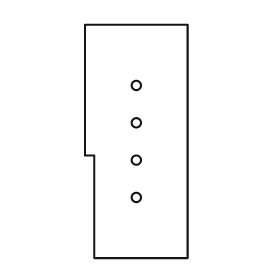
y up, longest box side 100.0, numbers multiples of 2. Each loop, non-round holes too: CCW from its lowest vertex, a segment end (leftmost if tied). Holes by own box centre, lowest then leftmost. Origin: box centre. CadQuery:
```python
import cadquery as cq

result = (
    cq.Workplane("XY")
    .moveTo(-18.0, -50.0)
    .lineTo(22.0, -50.0)
    .lineTo(22.0, 50.0)
    .lineTo(-22.0, 50.0)
    .lineTo(-22.0, -6.0)
    .lineTo(-18.0, -6.0)
    .close()
    .moveTo(0.0, -24.0)
    .circle(2.0)
    .moveTo(0.0, -8.0)
    .circle(2.0)
    .moveTo(0.0, 8.0)
    .circle(2.0)
    .moveTo(0.0, 24.0)
    .circle(2.0)
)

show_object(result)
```